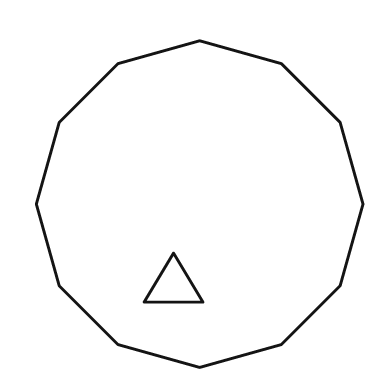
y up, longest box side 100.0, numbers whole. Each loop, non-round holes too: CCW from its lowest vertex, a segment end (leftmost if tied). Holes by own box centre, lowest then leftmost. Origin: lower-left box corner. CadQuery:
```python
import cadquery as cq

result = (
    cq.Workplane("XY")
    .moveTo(50.0, 0.0)
    .lineTo(75.0, 7.0)
    .lineTo(93.0, 25.0)
    .lineTo(100.0, 50.0)
    .lineTo(93.0, 75.0)
    .lineTo(75.0, 93.0)
    .lineTo(50.0, 100.0)
    .lineTo(25.0, 93.0)
    .lineTo(7.0, 75.0)
    .lineTo(0.0, 50.0)
    .lineTo(7.0, 25.0)
    .lineTo(25.0, 7.0)
    .close()
    .moveTo(33.0, 20.0)
    .lineTo(51.0, 20.0)
    .lineTo(42.0, 35.0)
    .close()
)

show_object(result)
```